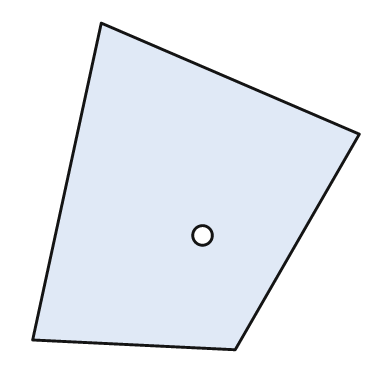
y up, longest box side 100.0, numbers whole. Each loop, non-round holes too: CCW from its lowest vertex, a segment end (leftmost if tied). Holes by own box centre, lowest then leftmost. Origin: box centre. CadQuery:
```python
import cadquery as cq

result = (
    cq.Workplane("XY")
    .moveTo(12.0, -50.0)
    .lineTo(50.0, 16.0)
    .lineTo(-29.0, 50.0)
    .lineTo(-50.0, -47.0)
    .close()
    .moveTo(2.0, -15.0)
    .circle(3.0)
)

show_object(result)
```